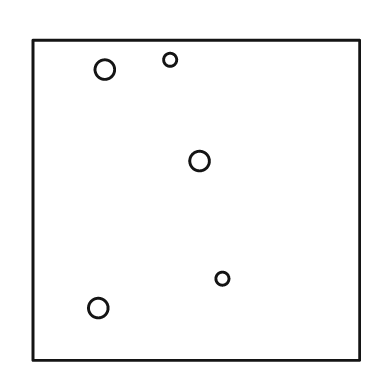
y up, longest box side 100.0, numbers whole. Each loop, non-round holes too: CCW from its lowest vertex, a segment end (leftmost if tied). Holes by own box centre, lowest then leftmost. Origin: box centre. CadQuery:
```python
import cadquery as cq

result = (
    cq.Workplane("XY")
    .moveTo(-50.0, -49.0)
    .lineTo(50.0, -49.0)
    .lineTo(50.0, 49.0)
    .lineTo(-50.0, 49.0)
    .close()
    .moveTo(-30.0, -33.0)
    .circle(3.0)
    .moveTo(8.0, -24.0)
    .circle(2.0)
    .moveTo(1.0, 12.0)
    .circle(3.0)
    .moveTo(-28.0, 40.0)
    .circle(3.0)
    .moveTo(-8.0, 43.0)
    .circle(2.0)
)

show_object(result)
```